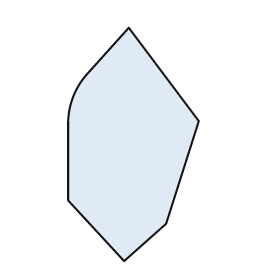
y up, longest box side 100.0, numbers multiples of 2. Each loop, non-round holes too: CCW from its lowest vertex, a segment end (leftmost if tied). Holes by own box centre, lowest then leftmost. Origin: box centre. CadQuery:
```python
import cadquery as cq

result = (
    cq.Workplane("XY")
    .moveTo(-4.0, -50.0)
    .lineTo(14.0, -34.0)
    .lineTo(28.0, 10.0)
    .lineTo(-2.0, 50.0)
    .lineTo(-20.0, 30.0)
    .threePointArc((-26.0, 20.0), (-28.0, 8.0))
    .lineTo(-28.0, -24.0)
    .close()
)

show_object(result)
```